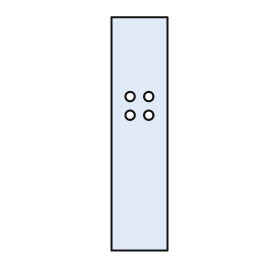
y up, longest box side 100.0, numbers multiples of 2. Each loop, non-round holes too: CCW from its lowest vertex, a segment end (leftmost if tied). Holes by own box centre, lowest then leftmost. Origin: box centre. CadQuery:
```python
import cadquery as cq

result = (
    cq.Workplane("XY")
    .moveTo(-12.0, -50.0)
    .lineTo(12.0, -50.0)
    .lineTo(12.0, 50.0)
    .lineTo(-12.0, 50.0)
    .close()
    .moveTo(-4.0, 8.0)
    .circle(2.0)
    .moveTo(4.0, 8.0)
    .circle(2.0)
    .moveTo(-4.0, 16.0)
    .circle(2.0)
    .moveTo(4.0, 16.0)
    .circle(2.0)
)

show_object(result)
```